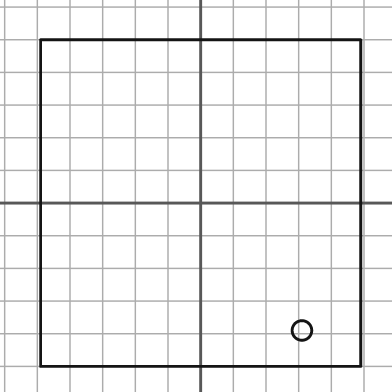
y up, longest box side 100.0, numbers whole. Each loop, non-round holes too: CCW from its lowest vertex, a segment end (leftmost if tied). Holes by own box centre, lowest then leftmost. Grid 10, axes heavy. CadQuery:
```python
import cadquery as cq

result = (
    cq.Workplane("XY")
    .moveTo(-49.0, -50.0)
    .lineTo(49.0, -50.0)
    .lineTo(49.0, 50.0)
    .lineTo(-49.0, 50.0)
    .close()
    .moveTo(31.0, -39.0)
    .circle(3.0)
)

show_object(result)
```